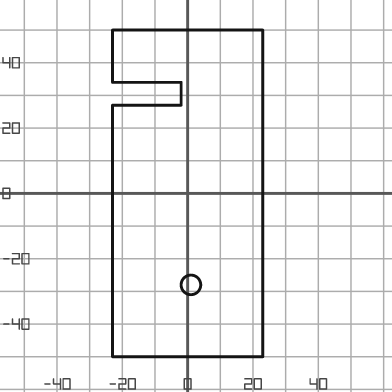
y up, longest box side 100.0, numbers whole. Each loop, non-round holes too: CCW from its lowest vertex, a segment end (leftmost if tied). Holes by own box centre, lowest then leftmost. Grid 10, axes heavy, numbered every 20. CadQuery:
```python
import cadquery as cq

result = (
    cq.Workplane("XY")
    .moveTo(-23.0, -50.0)
    .lineTo(23.0, -50.0)
    .lineTo(23.0, 50.0)
    .lineTo(-23.0, 50.0)
    .lineTo(-23.0, 34.0)
    .lineTo(-2.0, 34.0)
    .lineTo(-2.0, 27.0)
    .lineTo(-23.0, 27.0)
    .close()
    .moveTo(1.0, -28.0)
    .circle(3.0)
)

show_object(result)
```